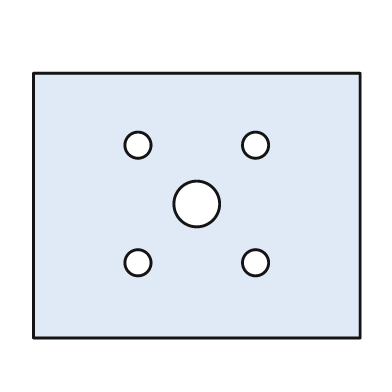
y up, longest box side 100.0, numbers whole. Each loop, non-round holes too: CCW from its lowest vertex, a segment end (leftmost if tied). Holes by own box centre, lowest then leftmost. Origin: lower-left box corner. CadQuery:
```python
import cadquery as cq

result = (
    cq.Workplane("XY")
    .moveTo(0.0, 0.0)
    .lineTo(100.0, 0.0)
    .lineTo(100.0, 81.0)
    .lineTo(0.0, 81.0)
    .close()
    .moveTo(32.0, 23.0)
    .circle(4.0)
    .moveTo(68.0, 23.0)
    .circle(4.0)
    .moveTo(50.0, 41.0)
    .circle(7.0)
    .moveTo(32.0, 59.0)
    .circle(4.0)
    .moveTo(68.0, 59.0)
    .circle(4.0)
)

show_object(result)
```